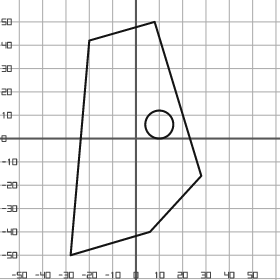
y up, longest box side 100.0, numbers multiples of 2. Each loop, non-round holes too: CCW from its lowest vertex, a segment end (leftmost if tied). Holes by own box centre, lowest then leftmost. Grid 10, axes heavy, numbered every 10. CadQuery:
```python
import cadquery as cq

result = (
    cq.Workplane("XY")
    .moveTo(-28.0, -50.0)
    .lineTo(6.0, -40.0)
    .lineTo(28.0, -16.0)
    .lineTo(8.0, 50.0)
    .lineTo(-20.0, 42.0)
    .close()
    .moveTo(10.0, 6.0)
    .circle(6.0)
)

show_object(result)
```